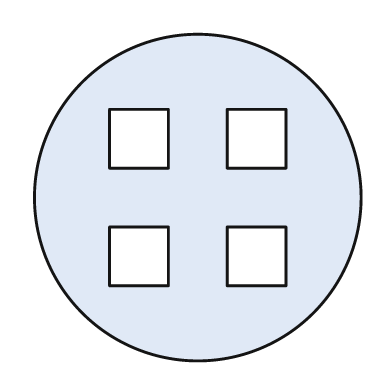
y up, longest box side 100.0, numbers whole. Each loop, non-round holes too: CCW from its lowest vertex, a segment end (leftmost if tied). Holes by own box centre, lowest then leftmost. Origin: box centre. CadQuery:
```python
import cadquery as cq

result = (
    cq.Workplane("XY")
    .moveTo(0.0, 0.0)
    .circle(50.0)
    .moveTo(-27.0, -27.0)
    .lineTo(-9.0, -27.0)
    .lineTo(-9.0, -9.0)
    .lineTo(-27.0, -9.0)
    .close()
    .moveTo(9.0, -27.0)
    .lineTo(27.0, -27.0)
    .lineTo(27.0, -9.0)
    .lineTo(9.0, -9.0)
    .close()
    .moveTo(-27.0, 9.0)
    .lineTo(-9.0, 9.0)
    .lineTo(-9.0, 27.0)
    .lineTo(-27.0, 27.0)
    .close()
    .moveTo(9.0, 9.0)
    .lineTo(27.0, 9.0)
    .lineTo(27.0, 27.0)
    .lineTo(9.0, 27.0)
    .close()
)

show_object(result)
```